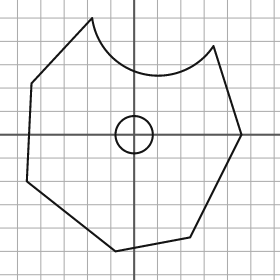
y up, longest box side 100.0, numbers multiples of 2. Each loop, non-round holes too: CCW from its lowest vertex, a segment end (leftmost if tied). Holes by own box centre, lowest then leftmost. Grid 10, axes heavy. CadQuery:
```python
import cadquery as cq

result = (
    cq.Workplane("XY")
    .moveTo(-8.0, -50.0)
    .lineTo(24.0, -44.0)
    .lineTo(46.0, 0.0)
    .lineTo(34.0, 38.0)
    .threePointArc((4.0, 26.0), (-18.0, 50.0))
    .lineTo(-44.0, 22.0)
    .lineTo(-46.0, -20.0)
    .close()
    .moveTo(0.0, 0.0)
    .circle(8.0)
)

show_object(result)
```